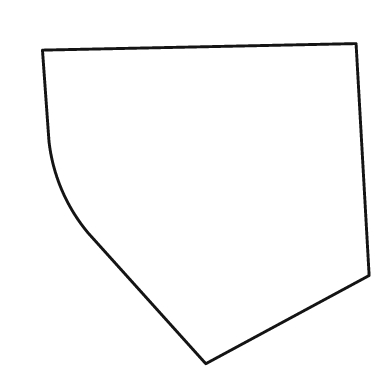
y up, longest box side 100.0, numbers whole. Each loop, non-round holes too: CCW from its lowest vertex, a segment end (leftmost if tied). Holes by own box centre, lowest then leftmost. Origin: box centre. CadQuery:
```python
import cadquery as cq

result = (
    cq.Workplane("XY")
    .moveTo(0.0, -49.0)
    .lineTo(50.0, -22.0)
    .lineTo(46.0, 49.0)
    .lineTo(-50.0, 47.0)
    .lineTo(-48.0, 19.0)
    .threePointArc((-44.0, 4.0), (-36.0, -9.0))
    .close()
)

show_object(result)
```